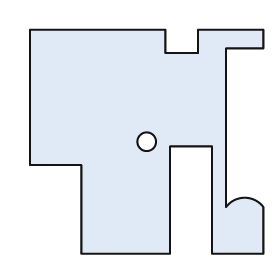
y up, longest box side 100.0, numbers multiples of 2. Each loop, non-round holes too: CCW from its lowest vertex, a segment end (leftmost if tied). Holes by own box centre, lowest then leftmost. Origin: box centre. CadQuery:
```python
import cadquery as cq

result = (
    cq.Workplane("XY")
    .moveTo(-28.0, -48.0)
    .lineTo(10.0, -48.0)
    .lineTo(10.0, -2.0)
    .lineTo(28.0, -2.0)
    .lineTo(28.0, -48.0)
    .lineTo(50.0, -48.0)
    .lineTo(50.0, -28.0)
    .threePointArc((42.0, -24.0), (34.0, -28.0))
    .lineTo(34.0, 40.0)
    .lineTo(50.0, 40.0)
    .lineTo(50.0, 48.0)
    .lineTo(22.0, 48.0)
    .lineTo(22.0, 38.0)
    .lineTo(8.0, 38.0)
    .lineTo(8.0, 48.0)
    .lineTo(-50.0, 48.0)
    .lineTo(-50.0, -10.0)
    .lineTo(-28.0, -10.0)
    .close()
    .moveTo(0.0, 0.0)
    .circle(4.0)
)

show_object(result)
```